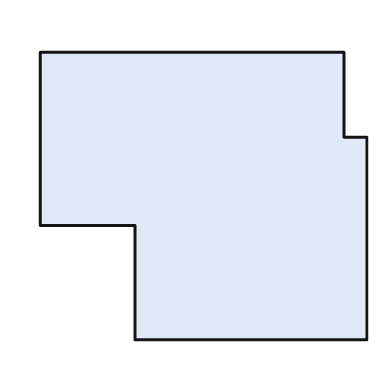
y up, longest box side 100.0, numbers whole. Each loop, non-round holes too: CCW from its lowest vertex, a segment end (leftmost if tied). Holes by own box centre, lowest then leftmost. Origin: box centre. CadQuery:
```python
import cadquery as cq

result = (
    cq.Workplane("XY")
    .moveTo(-21.0, -44.0)
    .lineTo(50.0, -44.0)
    .lineTo(50.0, 18.0)
    .lineTo(43.0, 18.0)
    .lineTo(43.0, 44.0)
    .lineTo(-50.0, 44.0)
    .lineTo(-50.0, -9.0)
    .lineTo(-21.0, -9.0)
    .close()
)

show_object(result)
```